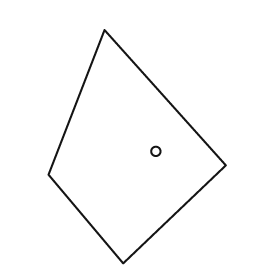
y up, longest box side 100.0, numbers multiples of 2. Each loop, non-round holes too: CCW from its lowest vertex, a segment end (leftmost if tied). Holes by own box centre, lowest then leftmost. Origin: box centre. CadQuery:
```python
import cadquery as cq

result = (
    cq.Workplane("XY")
    .moveTo(-6.0, -50.0)
    .lineTo(38.0, -8.0)
    .lineTo(-14.0, 50.0)
    .lineTo(-38.0, -12.0)
    .close()
    .moveTo(8.0, -2.0)
    .circle(2.0)
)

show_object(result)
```